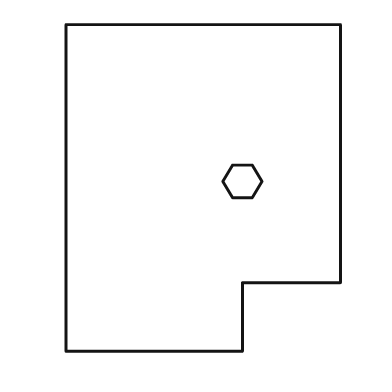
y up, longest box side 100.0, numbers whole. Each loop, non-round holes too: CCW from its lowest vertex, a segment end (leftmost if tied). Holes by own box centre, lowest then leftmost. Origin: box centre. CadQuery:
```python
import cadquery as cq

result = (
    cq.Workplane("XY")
    .moveTo(-42.0, -50.0)
    .lineTo(12.0, -50.0)
    .lineTo(12.0, -29.0)
    .lineTo(42.0, -29.0)
    .lineTo(42.0, 50.0)
    .lineTo(-42.0, 50.0)
    .close()
    .moveTo(9.0, -3.0)
    .lineTo(15.0, -3.0)
    .lineTo(18.0, 2.0)
    .lineTo(15.0, 7.0)
    .lineTo(9.0, 7.0)
    .lineTo(6.0, 2.0)
    .close()
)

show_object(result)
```